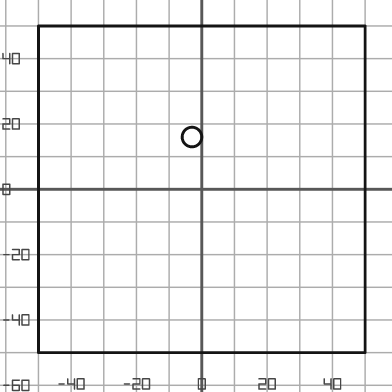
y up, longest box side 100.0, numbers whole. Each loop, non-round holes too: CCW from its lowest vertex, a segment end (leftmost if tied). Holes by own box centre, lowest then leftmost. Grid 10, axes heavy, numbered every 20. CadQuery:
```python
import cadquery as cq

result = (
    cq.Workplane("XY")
    .moveTo(-50.0, -50.0)
    .lineTo(50.0, -50.0)
    .lineTo(50.0, 50.0)
    .lineTo(-50.0, 50.0)
    .close()
    .moveTo(-3.0, 16.0)
    .circle(3.0)
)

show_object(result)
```